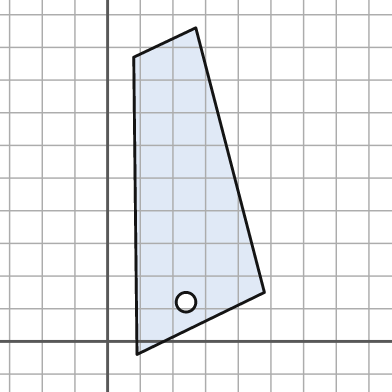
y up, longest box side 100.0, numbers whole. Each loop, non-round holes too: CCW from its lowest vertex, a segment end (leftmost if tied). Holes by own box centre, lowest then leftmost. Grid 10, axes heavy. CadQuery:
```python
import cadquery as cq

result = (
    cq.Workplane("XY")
    .moveTo(9.0, -4.0)
    .lineTo(48.0, 15.0)
    .lineTo(27.0, 96.0)
    .lineTo(8.0, 87.0)
    .close()
    .moveTo(24.0, 12.0)
    .circle(3.0)
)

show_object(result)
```